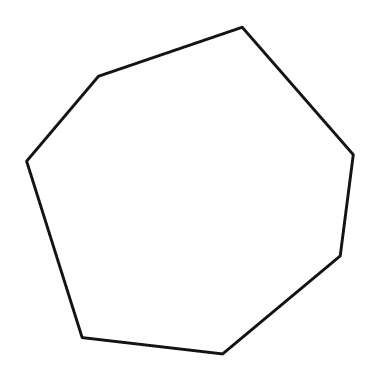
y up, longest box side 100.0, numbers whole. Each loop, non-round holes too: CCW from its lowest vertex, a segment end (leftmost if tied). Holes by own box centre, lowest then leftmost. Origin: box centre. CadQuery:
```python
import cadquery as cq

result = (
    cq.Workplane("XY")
    .moveTo(10.0, -50.0)
    .lineTo(46.0, -20.0)
    .lineTo(50.0, 11.0)
    .lineTo(16.0, 50.0)
    .lineTo(-28.0, 35.0)
    .lineTo(-50.0, 9.0)
    .lineTo(-33.0, -45.0)
    .close()
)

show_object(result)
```